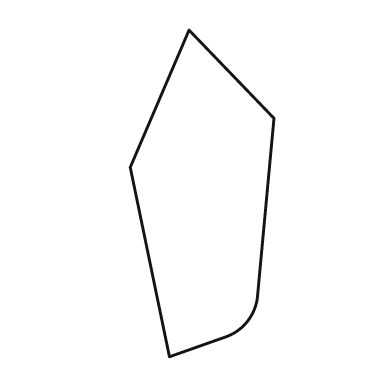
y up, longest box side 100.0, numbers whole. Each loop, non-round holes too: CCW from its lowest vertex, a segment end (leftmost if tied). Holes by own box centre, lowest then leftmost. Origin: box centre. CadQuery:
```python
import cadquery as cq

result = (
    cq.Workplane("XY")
    .moveTo(-10.0, -50.0)
    .lineTo(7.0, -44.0)
    .threePointArc((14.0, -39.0), (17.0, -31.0))
    .lineTo(22.0, 23.0)
    .lineTo(-4.0, 50.0)
    .lineTo(-22.0, 8.0)
    .close()
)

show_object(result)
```